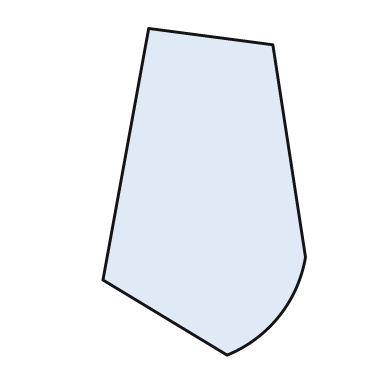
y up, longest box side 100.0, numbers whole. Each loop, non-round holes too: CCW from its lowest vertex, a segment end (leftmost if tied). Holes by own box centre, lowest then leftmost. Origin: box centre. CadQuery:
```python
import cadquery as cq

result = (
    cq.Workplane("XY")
    .moveTo(7.0, -50.0)
    .threePointArc((23.0, -38.0), (31.0, -20.0))
    .lineTo(21.0, 45.0)
    .lineTo(-17.0, 50.0)
    .lineTo(-31.0, -27.0)
    .close()
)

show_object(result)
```